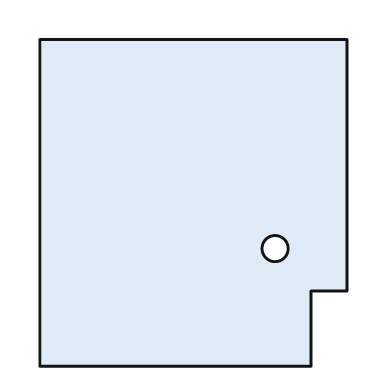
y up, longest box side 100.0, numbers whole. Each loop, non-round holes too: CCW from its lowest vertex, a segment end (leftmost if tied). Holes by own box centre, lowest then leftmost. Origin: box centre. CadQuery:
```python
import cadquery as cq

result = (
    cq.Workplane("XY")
    .moveTo(-47.0, -50.0)
    .lineTo(36.0, -50.0)
    .lineTo(36.0, -27.0)
    .lineTo(47.0, -27.0)
    .lineTo(47.0, 50.0)
    .lineTo(-47.0, 50.0)
    .close()
    .moveTo(25.0, -14.0)
    .circle(4.0)
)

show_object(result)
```